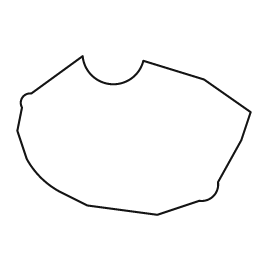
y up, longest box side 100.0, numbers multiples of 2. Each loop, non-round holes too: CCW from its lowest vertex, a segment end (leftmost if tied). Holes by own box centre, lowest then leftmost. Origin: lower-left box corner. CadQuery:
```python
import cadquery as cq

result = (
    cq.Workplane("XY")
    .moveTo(60.0, 0.0)
    .lineTo(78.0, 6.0)
    .threePointArc((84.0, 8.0), (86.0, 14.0))
    .lineTo(96.0, 32.0)
    .lineTo(100.0, 44.0)
    .lineTo(80.0, 58.0)
    .lineTo(54.0, 66.0)
    .threePointArc((40.0, 56.0), (28.0, 68.0))
    .lineTo(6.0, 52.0)
    .threePointArc((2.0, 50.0), (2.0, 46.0))
    .lineTo(0.0, 36.0)
    .lineTo(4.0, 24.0)
    .threePointArc((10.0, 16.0), (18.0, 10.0))
    .lineTo(30.0, 4.0)
    .close()
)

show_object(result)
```